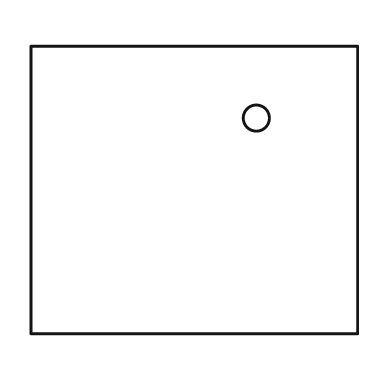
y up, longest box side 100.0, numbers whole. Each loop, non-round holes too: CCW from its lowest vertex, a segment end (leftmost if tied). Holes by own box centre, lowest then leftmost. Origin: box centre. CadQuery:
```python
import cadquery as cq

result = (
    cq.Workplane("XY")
    .moveTo(-50.0, -44.0)
    .lineTo(50.0, -44.0)
    .lineTo(50.0, 44.0)
    .lineTo(-50.0, 44.0)
    .close()
    .moveTo(19.0, 22.0)
    .circle(4.0)
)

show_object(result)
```